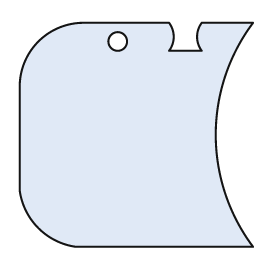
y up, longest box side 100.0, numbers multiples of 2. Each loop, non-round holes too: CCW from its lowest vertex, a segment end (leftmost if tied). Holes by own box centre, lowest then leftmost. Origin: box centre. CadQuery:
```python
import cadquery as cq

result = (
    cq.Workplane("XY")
    .moveTo(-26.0, -48.0)
    .lineTo(50.0, -48.0)
    .threePointArc((34.0, 0.0), (50.0, 48.0))
    .lineTo(28.0, 48.0)
    .threePointArc((26.0, 42.0), (28.0, 36.0))
    .lineTo(14.0, 36.0)
    .threePointArc((16.0, 42.0), (14.0, 48.0))
    .lineTo(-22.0, 48.0)
    .threePointArc((-42.0, 40.0), (-50.0, 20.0))
    .lineTo(-50.0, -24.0)
    .threePointArc((-42.0, -40.0), (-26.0, -48.0))
    .close()
    .moveTo(-8.0, 40.0)
    .circle(4.0)
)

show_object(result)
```